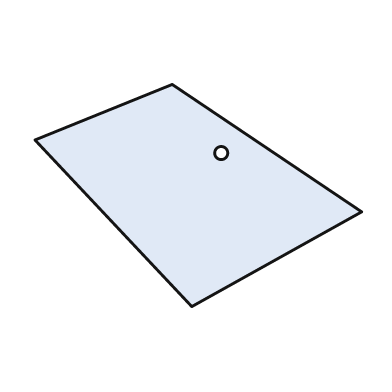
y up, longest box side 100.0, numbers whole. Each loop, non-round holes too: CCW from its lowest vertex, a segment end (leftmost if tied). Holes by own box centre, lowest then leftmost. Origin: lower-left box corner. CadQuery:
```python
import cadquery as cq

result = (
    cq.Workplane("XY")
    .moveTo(48.0, 0.0)
    .lineTo(100.0, 29.0)
    .lineTo(42.0, 68.0)
    .lineTo(0.0, 51.0)
    .close()
    .moveTo(57.0, 47.0)
    .circle(2.0)
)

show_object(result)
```